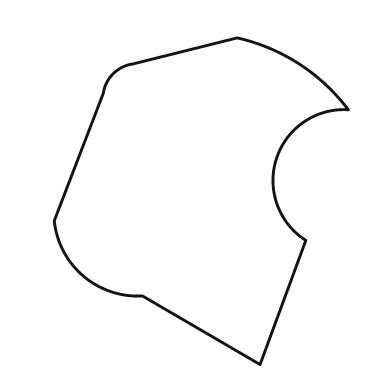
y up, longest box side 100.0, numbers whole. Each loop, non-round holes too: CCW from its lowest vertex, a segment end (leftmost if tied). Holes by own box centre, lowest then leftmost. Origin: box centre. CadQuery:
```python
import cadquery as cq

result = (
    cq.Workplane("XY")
    .moveTo(18.0, -50.0)
    .lineTo(32.0, -12.0)
    .threePointArc((23.0, 13.0), (45.0, 28.0))
    .threePointArc((30.0, 42.0), (11.0, 50.0))
    .lineTo(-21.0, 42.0)
    .threePointArc((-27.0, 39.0), (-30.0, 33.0))
    .lineTo(-45.0, -6.0)
    .threePointArc((-36.0, -23.0), (-18.0, -29.0))
    .close()
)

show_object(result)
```